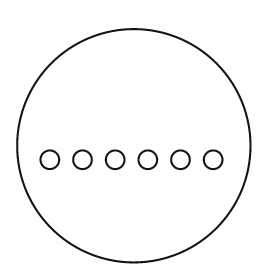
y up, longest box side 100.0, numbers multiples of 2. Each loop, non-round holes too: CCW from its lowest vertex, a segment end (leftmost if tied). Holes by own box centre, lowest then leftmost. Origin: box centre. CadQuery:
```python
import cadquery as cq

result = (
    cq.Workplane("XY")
    .moveTo(0.0, 0.0)
    .circle(50.0)
    .moveTo(-36.0, -6.0)
    .circle(4.0)
    .moveTo(-22.0, -6.0)
    .circle(4.0)
    .moveTo(-8.0, -6.0)
    .circle(4.0)
    .moveTo(6.0, -6.0)
    .circle(4.0)
    .moveTo(20.0, -6.0)
    .circle(4.0)
    .moveTo(34.0, -6.0)
    .circle(4.0)
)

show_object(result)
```